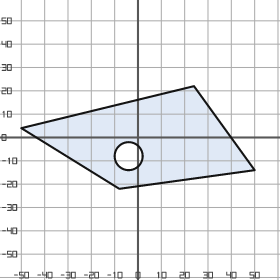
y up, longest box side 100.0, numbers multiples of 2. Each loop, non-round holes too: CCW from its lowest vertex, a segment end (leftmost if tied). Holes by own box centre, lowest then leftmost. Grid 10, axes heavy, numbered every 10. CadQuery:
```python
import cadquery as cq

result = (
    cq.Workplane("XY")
    .moveTo(-8.0, -22.0)
    .lineTo(50.0, -14.0)
    .lineTo(24.0, 22.0)
    .lineTo(-50.0, 4.0)
    .close()
    .moveTo(-4.0, -8.0)
    .circle(6.0)
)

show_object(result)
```